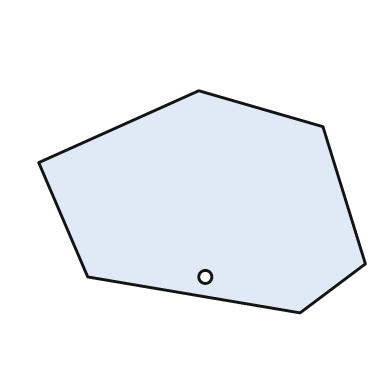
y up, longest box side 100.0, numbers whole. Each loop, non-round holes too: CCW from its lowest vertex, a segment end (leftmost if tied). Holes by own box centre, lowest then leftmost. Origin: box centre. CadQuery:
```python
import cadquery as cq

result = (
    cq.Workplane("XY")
    .moveTo(30.0, -34.0)
    .lineTo(50.0, -19.0)
    .lineTo(37.0, 23.0)
    .lineTo(-1.0, 34.0)
    .lineTo(-50.0, 12.0)
    .lineTo(-35.0, -23.0)
    .close()
    .moveTo(1.0, -23.0)
    .circle(2.0)
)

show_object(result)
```